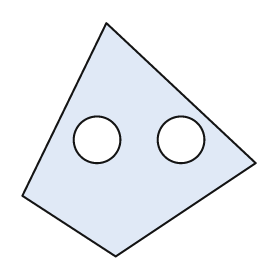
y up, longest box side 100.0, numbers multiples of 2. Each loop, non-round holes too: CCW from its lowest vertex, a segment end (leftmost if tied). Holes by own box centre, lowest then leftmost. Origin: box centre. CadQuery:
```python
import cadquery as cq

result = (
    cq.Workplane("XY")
    .moveTo(-10.0, -50.0)
    .lineTo(50.0, -10.0)
    .lineTo(-14.0, 50.0)
    .lineTo(-50.0, -24.0)
    .close()
    .moveTo(-18.0, 0.0)
    .circle(10.0)
    .moveTo(18.0, 0.0)
    .circle(10.0)
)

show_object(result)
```